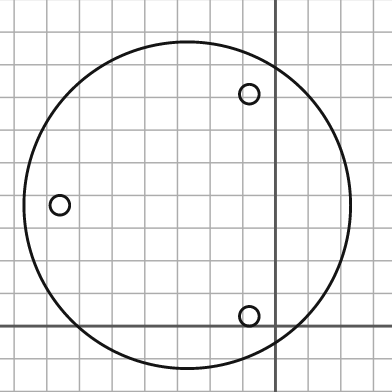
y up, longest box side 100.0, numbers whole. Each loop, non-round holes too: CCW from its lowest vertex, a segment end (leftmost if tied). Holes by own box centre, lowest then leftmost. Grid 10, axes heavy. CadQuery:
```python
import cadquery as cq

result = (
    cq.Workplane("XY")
    .moveTo(-27.0, 37.0)
    .circle(50.0)
    .moveTo(-8.0, 3.0)
    .circle(3.0)
    .moveTo(-66.0, 37.0)
    .circle(3.0)
    .moveTo(-8.0, 71.0)
    .circle(3.0)
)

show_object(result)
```